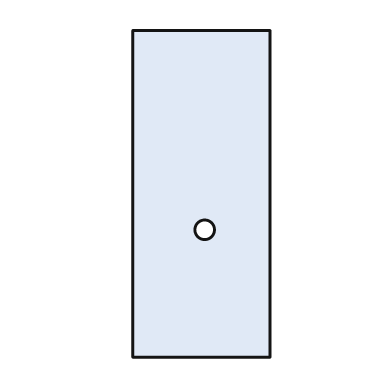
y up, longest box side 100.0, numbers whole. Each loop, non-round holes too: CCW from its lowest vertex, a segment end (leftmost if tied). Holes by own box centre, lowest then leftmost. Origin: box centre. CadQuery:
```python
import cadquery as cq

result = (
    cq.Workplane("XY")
    .moveTo(-21.0, -50.0)
    .lineTo(21.0, -50.0)
    .lineTo(21.0, 50.0)
    .lineTo(-21.0, 50.0)
    .close()
    .moveTo(1.0, -11.0)
    .circle(3.0)
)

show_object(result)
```